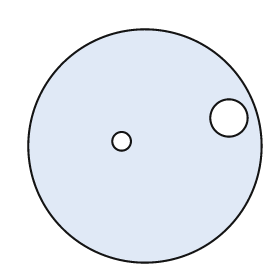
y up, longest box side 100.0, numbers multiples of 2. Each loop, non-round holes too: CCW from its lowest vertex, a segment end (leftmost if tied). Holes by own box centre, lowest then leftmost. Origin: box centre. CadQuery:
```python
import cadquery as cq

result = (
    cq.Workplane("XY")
    .moveTo(0.0, 0.0)
    .circle(50.0)
    .moveTo(-10.0, 2.0)
    .circle(4.0)
    .moveTo(36.0, 12.0)
    .circle(8.0)
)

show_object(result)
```